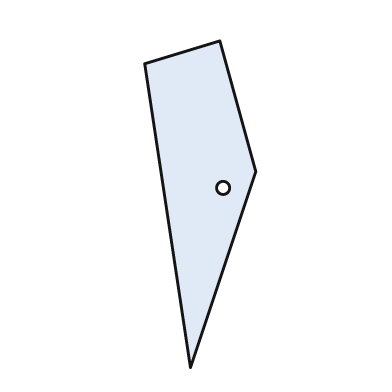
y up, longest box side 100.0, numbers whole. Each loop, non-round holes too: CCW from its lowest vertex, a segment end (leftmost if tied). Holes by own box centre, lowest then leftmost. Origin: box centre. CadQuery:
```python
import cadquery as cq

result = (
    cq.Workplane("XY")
    .moveTo(-3.0, -50.0)
    .lineTo(17.0, 10.0)
    .lineTo(6.0, 50.0)
    .lineTo(-17.0, 43.0)
    .close()
    .moveTo(7.0, 5.0)
    .circle(2.0)
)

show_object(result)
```